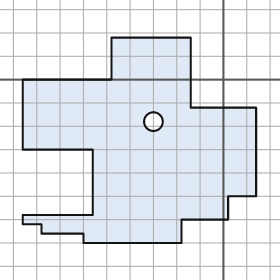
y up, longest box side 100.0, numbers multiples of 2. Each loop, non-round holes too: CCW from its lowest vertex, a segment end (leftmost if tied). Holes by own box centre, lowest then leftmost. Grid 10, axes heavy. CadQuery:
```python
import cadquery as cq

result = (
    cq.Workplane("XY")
    .moveTo(-60.0, -70.0)
    .lineTo(-18.0, -70.0)
    .lineTo(-18.0, -60.0)
    .lineTo(2.0, -60.0)
    .lineTo(2.0, -50.0)
    .lineTo(14.0, -50.0)
    .lineTo(14.0, -12.0)
    .lineTo(-14.0, -12.0)
    .lineTo(-14.0, 18.0)
    .lineTo(-48.0, 18.0)
    .lineTo(-48.0, 0.0)
    .lineTo(-86.0, 0.0)
    .lineTo(-86.0, -30.0)
    .lineTo(-56.0, -30.0)
    .lineTo(-56.0, -58.0)
    .lineTo(-86.0, -58.0)
    .lineTo(-86.0, -62.0)
    .lineTo(-78.0, -62.0)
    .lineTo(-78.0, -66.0)
    .lineTo(-60.0, -66.0)
    .close()
    .moveTo(-30.0, -18.0)
    .circle(4.0)
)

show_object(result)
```